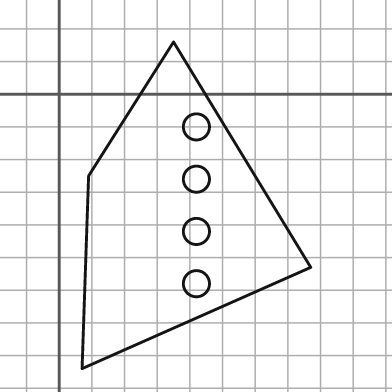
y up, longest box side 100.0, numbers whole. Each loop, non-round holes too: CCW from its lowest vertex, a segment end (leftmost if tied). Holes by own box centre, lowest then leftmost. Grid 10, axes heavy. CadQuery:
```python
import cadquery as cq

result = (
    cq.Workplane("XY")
    .moveTo(7.0, -84.0)
    .lineTo(77.0, -53.0)
    .lineTo(35.0, 16.0)
    .lineTo(9.0, -25.0)
    .close()
    .moveTo(42.0, -58.0)
    .circle(4.0)
    .moveTo(42.0, -42.0)
    .circle(4.0)
    .moveTo(42.0, -26.0)
    .circle(4.0)
    .moveTo(42.0, -10.0)
    .circle(4.0)
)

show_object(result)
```